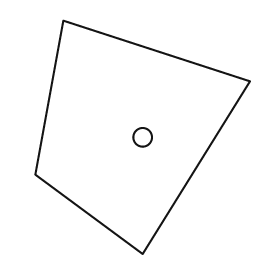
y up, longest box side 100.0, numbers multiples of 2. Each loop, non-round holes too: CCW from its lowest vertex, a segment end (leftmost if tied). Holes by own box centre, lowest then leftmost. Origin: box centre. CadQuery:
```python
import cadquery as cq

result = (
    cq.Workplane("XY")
    .moveTo(0.0, -50.0)
    .lineTo(46.0, 24.0)
    .lineTo(-34.0, 50.0)
    .lineTo(-46.0, -16.0)
    .close()
    .moveTo(0.0, 0.0)
    .circle(4.0)
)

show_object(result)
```